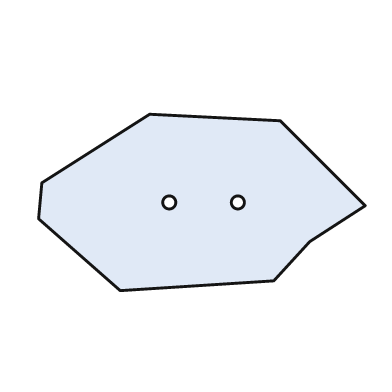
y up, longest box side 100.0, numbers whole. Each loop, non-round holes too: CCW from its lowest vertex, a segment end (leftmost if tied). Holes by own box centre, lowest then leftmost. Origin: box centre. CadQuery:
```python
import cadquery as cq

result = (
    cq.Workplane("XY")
    .moveTo(-25.0, -27.0)
    .lineTo(22.0, -24.0)
    .lineTo(33.0, -12.0)
    .lineTo(50.0, -1.0)
    .lineTo(24.0, 25.0)
    .lineTo(-16.0, 27.0)
    .lineTo(-49.0, 6.0)
    .lineTo(-50.0, -5.0)
    .close()
    .moveTo(-10.0, 0.0)
    .circle(2.0)
    .moveTo(11.0, 0.0)
    .circle(2.0)
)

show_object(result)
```